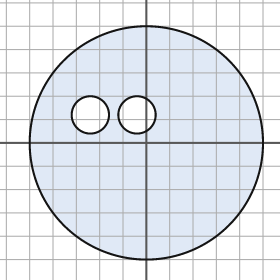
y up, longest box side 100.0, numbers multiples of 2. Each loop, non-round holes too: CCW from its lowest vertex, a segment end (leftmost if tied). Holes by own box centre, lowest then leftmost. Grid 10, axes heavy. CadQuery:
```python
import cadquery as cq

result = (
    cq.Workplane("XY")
    .moveTo(0.0, 0.0)
    .circle(50.0)
    .moveTo(-24.0, 12.0)
    .circle(8.0)
    .moveTo(-4.0, 12.0)
    .circle(8.0)
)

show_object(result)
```